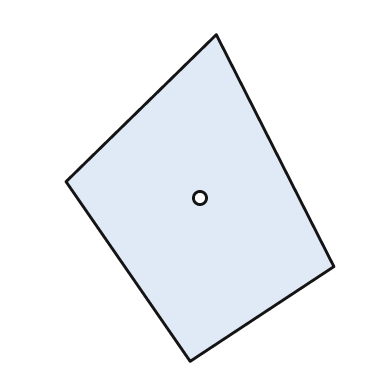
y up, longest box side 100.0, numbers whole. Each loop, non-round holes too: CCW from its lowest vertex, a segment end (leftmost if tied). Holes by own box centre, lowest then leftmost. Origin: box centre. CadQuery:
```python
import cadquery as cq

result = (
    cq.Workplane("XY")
    .moveTo(-3.0, -50.0)
    .lineTo(41.0, -21.0)
    .lineTo(5.0, 50.0)
    .lineTo(-41.0, 5.0)
    .close()
    .moveTo(0.0, 0.0)
    .circle(2.0)
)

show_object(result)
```